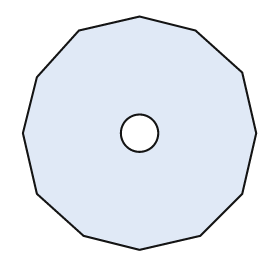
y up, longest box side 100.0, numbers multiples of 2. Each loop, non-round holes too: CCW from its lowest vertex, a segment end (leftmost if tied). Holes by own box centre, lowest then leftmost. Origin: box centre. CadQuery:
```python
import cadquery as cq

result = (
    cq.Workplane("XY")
    .moveTo(0.0, -50.0)
    .lineTo(26.0, -44.0)
    .lineTo(44.0, -26.0)
    .lineTo(50.0, 0.0)
    .lineTo(44.0, 26.0)
    .lineTo(24.0, 44.0)
    .lineTo(0.0, 50.0)
    .lineTo(-26.0, 44.0)
    .lineTo(-44.0, 24.0)
    .lineTo(-50.0, 0.0)
    .lineTo(-44.0, -26.0)
    .lineTo(-24.0, -44.0)
    .close()
    .moveTo(0.0, 0.0)
    .circle(8.0)
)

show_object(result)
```